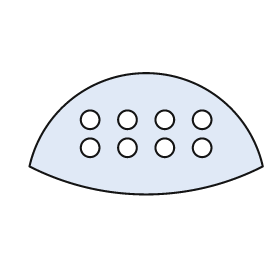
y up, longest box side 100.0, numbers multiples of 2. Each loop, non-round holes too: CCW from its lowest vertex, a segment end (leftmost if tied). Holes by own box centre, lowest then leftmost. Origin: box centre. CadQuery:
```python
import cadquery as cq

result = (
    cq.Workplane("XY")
    .moveTo(-50.0, -14.0)
    .threePointArc((0.0, -26.0), (50.0, -14.0))
    .threePointArc((0.0, 26.0), (-50.0, -14.0))
    .close()
    .moveTo(-24.0, -6.0)
    .circle(4.0)
    .moveTo(-8.0, -6.0)
    .circle(4.0)
    .moveTo(8.0, -6.0)
    .circle(4.0)
    .moveTo(24.0, -6.0)
    .circle(4.0)
    .moveTo(-24.0, 6.0)
    .circle(4.0)
    .moveTo(-8.0, 6.0)
    .circle(4.0)
    .moveTo(8.0, 6.0)
    .circle(4.0)
    .moveTo(24.0, 6.0)
    .circle(4.0)
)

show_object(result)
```